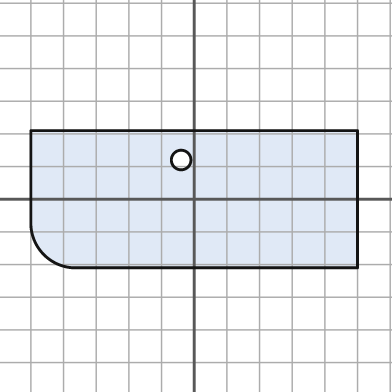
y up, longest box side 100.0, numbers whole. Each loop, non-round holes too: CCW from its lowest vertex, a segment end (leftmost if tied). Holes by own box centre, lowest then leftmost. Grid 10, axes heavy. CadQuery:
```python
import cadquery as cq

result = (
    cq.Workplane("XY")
    .moveTo(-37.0, -21.0)
    .lineTo(50.0, -21.0)
    .lineTo(50.0, 21.0)
    .lineTo(-50.0, 21.0)
    .lineTo(-50.0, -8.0)
    .threePointArc((-46.0, -17.0), (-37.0, -21.0))
    .close()
    .moveTo(-4.0, 12.0)
    .circle(3.0)
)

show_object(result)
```